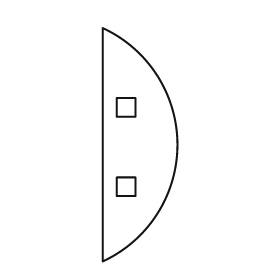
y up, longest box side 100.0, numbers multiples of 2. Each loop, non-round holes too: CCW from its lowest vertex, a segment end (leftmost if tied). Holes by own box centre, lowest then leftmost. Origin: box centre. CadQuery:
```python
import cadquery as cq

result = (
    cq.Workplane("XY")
    .moveTo(-16.0, -50.0)
    .threePointArc((16.0, 0.0), (-16.0, 50.0))
    .close()
    .moveTo(-10.0, -22.0)
    .lineTo(-2.0, -22.0)
    .lineTo(-2.0, -14.0)
    .lineTo(-10.0, -14.0)
    .close()
    .moveTo(-10.0, 12.0)
    .lineTo(-2.0, 12.0)
    .lineTo(-2.0, 20.0)
    .lineTo(-10.0, 20.0)
    .close()
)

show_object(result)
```